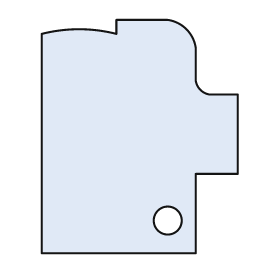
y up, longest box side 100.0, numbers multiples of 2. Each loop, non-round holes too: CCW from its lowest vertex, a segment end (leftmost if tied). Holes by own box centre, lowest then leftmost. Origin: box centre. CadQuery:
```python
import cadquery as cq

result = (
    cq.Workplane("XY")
    .moveTo(-42.0, -50.0)
    .lineTo(24.0, -50.0)
    .lineTo(24.0, -16.0)
    .lineTo(42.0, -16.0)
    .lineTo(42.0, 18.0)
    .lineTo(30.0, 18.0)
    .threePointArc((26.0, 20.0), (24.0, 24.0))
    .lineTo(24.0, 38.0)
    .threePointArc((20.0, 46.0), (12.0, 50.0))
    .lineTo(-10.0, 50.0)
    .lineTo(-10.0, 44.0)
    .threePointArc((-26.0, 46.0), (-42.0, 44.0))
    .close()
    .moveTo(12.0, -36.0)
    .circle(6.0)
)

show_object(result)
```